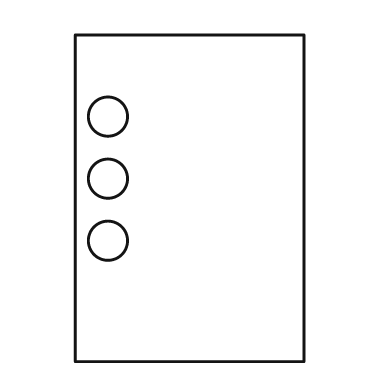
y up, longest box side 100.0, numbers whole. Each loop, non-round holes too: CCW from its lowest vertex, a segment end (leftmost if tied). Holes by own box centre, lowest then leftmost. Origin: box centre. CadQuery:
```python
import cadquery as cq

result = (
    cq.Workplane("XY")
    .moveTo(-35.0, -50.0)
    .lineTo(35.0, -50.0)
    .lineTo(35.0, 50.0)
    .lineTo(-35.0, 50.0)
    .close()
    .moveTo(-25.0, -13.0)
    .circle(6.0)
    .moveTo(-25.0, 6.0)
    .circle(6.0)
    .moveTo(-25.0, 25.0)
    .circle(6.0)
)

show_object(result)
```